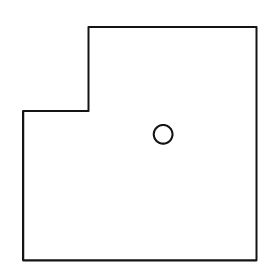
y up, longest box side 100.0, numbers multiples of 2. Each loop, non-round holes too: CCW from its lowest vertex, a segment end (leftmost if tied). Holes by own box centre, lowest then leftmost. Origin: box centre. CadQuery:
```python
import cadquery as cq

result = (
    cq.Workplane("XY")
    .moveTo(-50.0, -50.0)
    .lineTo(50.0, -50.0)
    .lineTo(50.0, 50.0)
    .lineTo(-22.0, 50.0)
    .lineTo(-22.0, 14.0)
    .lineTo(-50.0, 14.0)
    .close()
    .moveTo(10.0, 4.0)
    .circle(4.0)
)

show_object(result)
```